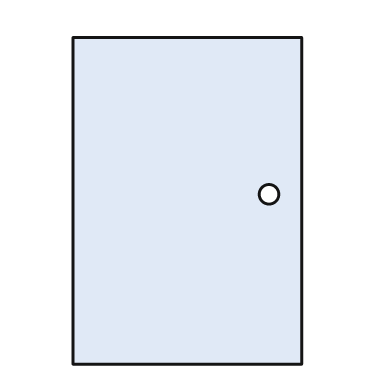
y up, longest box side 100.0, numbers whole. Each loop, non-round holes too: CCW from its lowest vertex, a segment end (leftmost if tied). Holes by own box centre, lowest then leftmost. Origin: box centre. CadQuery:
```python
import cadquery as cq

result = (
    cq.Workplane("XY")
    .moveTo(-35.0, -50.0)
    .lineTo(35.0, -50.0)
    .lineTo(35.0, 50.0)
    .lineTo(-35.0, 50.0)
    .close()
    .moveTo(25.0, 2.0)
    .circle(3.0)
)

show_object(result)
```